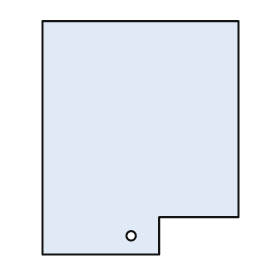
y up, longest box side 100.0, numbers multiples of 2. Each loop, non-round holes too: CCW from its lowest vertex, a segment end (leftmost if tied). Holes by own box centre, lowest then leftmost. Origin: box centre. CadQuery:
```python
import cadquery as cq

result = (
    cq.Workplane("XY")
    .moveTo(-42.0, -50.0)
    .lineTo(8.0, -50.0)
    .lineTo(8.0, -34.0)
    .lineTo(42.0, -34.0)
    .lineTo(42.0, 50.0)
    .lineTo(-42.0, 50.0)
    .close()
    .moveTo(-4.0, -42.0)
    .circle(2.0)
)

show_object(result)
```